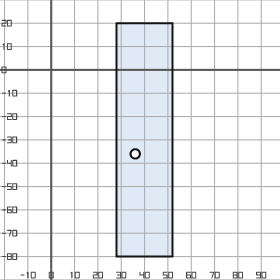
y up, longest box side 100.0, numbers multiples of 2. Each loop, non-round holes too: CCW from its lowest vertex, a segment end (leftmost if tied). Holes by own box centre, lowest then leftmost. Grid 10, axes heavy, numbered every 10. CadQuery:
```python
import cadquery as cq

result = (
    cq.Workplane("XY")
    .moveTo(28.0, -80.0)
    .lineTo(52.0, -80.0)
    .lineTo(52.0, 20.0)
    .lineTo(28.0, 20.0)
    .close()
    .moveTo(36.0, -36.0)
    .circle(2.0)
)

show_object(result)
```